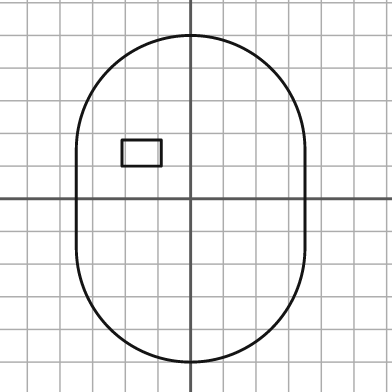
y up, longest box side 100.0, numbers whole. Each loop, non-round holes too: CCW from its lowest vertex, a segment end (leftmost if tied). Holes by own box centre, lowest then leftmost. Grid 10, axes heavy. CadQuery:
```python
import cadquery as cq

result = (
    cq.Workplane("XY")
    .moveTo(-35.0, -15.0)
    .threePointArc((0.0, -50.0), (35.0, -15.0))
    .lineTo(35.0, 15.0)
    .threePointArc((0.0, 50.0), (-35.0, 15.0))
    .close()
    .moveTo(-21.0, 10.0)
    .lineTo(-9.0, 10.0)
    .lineTo(-9.0, 18.0)
    .lineTo(-21.0, 18.0)
    .close()
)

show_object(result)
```